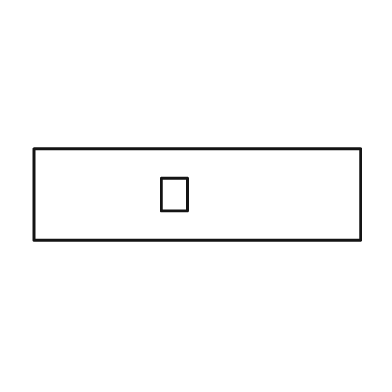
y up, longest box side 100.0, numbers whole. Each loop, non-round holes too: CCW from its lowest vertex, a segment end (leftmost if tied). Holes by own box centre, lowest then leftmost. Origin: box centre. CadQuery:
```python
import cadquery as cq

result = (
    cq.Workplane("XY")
    .moveTo(-50.0, -14.0)
    .lineTo(50.0, -14.0)
    .lineTo(50.0, 14.0)
    .lineTo(-50.0, 14.0)
    .close()
    .moveTo(-11.0, -5.0)
    .lineTo(-3.0, -5.0)
    .lineTo(-3.0, 5.0)
    .lineTo(-11.0, 5.0)
    .close()
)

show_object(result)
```